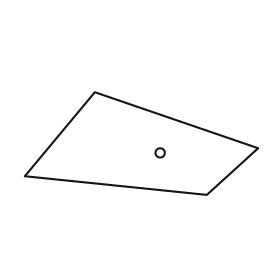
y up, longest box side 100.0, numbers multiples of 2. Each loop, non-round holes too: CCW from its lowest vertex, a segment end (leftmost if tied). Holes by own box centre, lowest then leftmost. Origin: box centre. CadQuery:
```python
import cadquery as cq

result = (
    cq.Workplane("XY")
    .moveTo(28.0, -22.0)
    .lineTo(50.0, -2.0)
    .lineTo(-20.0, 22.0)
    .lineTo(-50.0, -14.0)
    .close()
    .moveTo(8.0, -4.0)
    .circle(2.0)
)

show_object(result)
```